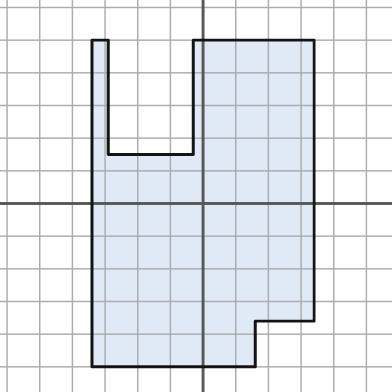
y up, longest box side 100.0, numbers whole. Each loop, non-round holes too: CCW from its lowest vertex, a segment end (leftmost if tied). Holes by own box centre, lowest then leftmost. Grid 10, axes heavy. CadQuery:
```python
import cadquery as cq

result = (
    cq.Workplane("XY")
    .moveTo(-34.0, -50.0)
    .lineTo(16.0, -50.0)
    .lineTo(16.0, -36.0)
    .lineTo(34.0, -36.0)
    .lineTo(34.0, 50.0)
    .lineTo(-3.0, 50.0)
    .lineTo(-3.0, 15.0)
    .lineTo(-29.0, 15.0)
    .lineTo(-29.0, 50.0)
    .lineTo(-34.0, 50.0)
    .close()
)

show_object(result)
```